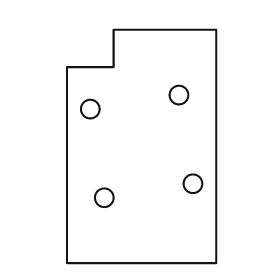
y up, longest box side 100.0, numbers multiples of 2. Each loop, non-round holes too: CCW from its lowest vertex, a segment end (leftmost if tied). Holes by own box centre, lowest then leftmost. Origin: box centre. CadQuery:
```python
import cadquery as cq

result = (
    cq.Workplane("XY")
    .moveTo(-32.0, -50.0)
    .lineTo(32.0, -50.0)
    .lineTo(32.0, 50.0)
    .lineTo(-12.0, 50.0)
    .lineTo(-12.0, 34.0)
    .lineTo(-32.0, 34.0)
    .close()
    .moveTo(-16.0, -22.0)
    .circle(4.0)
    .moveTo(22.0, -16.0)
    .circle(4.0)
    .moveTo(-22.0, 16.0)
    .circle(4.0)
    .moveTo(16.0, 22.0)
    .circle(4.0)
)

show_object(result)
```